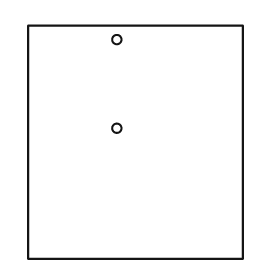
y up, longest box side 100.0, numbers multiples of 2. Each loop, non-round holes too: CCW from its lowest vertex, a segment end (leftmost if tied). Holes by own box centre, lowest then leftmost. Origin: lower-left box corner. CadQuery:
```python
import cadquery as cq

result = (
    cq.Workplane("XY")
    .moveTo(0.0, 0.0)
    .lineTo(92.0, 0.0)
    .lineTo(92.0, 100.0)
    .lineTo(0.0, 100.0)
    .close()
    .moveTo(38.0, 56.0)
    .circle(2.0)
    .moveTo(38.0, 94.0)
    .circle(2.0)
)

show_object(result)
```